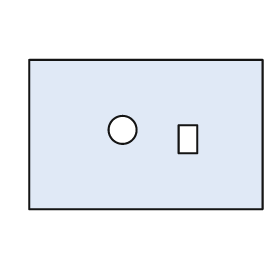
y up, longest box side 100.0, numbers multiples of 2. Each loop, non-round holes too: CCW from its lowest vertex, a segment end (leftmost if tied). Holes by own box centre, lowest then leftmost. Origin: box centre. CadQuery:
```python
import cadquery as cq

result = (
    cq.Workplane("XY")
    .moveTo(-50.0, -32.0)
    .lineTo(50.0, -32.0)
    .lineTo(50.0, 32.0)
    .lineTo(-50.0, 32.0)
    .close()
    .moveTo(14.0, -8.0)
    .lineTo(22.0, -8.0)
    .lineTo(22.0, 4.0)
    .lineTo(14.0, 4.0)
    .close()
    .moveTo(-10.0, 2.0)
    .circle(6.0)
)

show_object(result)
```